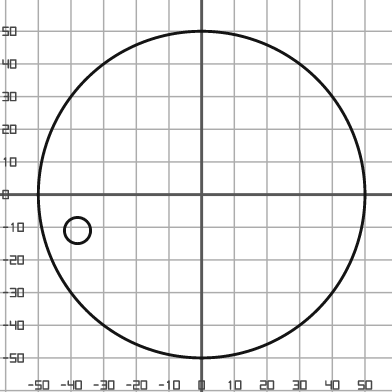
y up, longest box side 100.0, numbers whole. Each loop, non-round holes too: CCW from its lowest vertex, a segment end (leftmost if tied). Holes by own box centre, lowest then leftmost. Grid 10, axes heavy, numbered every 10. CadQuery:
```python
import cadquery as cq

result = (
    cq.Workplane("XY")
    .moveTo(0.0, 0.0)
    .circle(50.0)
    .moveTo(-38.0, -11.0)
    .circle(4.0)
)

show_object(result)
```